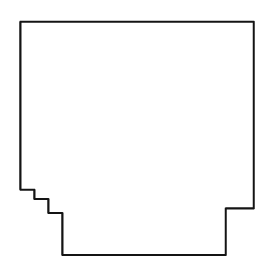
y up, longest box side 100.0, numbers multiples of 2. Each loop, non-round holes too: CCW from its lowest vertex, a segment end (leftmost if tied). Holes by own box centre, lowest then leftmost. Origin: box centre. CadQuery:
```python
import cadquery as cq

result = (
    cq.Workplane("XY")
    .moveTo(-32.0, -50.0)
    .lineTo(38.0, -50.0)
    .lineTo(38.0, -30.0)
    .lineTo(50.0, -30.0)
    .lineTo(50.0, 50.0)
    .lineTo(-50.0, 50.0)
    .lineTo(-50.0, -22.0)
    .lineTo(-44.0, -22.0)
    .lineTo(-44.0, -26.0)
    .lineTo(-38.0, -26.0)
    .lineTo(-38.0, -32.0)
    .lineTo(-32.0, -32.0)
    .close()
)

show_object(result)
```